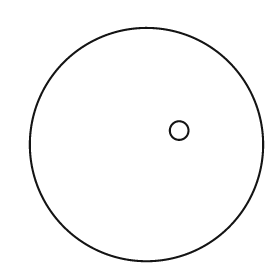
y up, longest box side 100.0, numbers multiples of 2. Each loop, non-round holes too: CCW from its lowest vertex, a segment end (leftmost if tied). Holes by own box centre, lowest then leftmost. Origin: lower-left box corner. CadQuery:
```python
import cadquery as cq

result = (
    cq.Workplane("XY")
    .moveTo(50.0, 50.0)
    .circle(50.0)
    .moveTo(64.0, 56.0)
    .circle(4.0)
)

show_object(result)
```